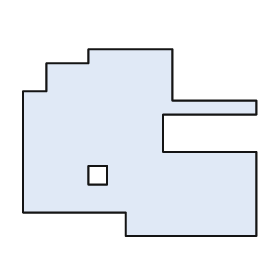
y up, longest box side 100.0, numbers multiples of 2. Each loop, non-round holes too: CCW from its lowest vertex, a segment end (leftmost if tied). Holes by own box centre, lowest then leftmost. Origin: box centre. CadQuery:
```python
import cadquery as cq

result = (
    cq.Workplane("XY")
    .moveTo(-6.0, -40.0)
    .lineTo(50.0, -40.0)
    .lineTo(50.0, -4.0)
    .lineTo(10.0, -4.0)
    .lineTo(10.0, 12.0)
    .lineTo(50.0, 12.0)
    .lineTo(50.0, 18.0)
    .lineTo(14.0, 18.0)
    .lineTo(14.0, 40.0)
    .lineTo(-22.0, 40.0)
    .lineTo(-22.0, 34.0)
    .lineTo(-40.0, 34.0)
    .lineTo(-40.0, 22.0)
    .lineTo(-50.0, 22.0)
    .lineTo(-50.0, -30.0)
    .lineTo(-6.0, -30.0)
    .close()
    .moveTo(-22.0, -18.0)
    .lineTo(-14.0, -18.0)
    .lineTo(-14.0, -10.0)
    .lineTo(-22.0, -10.0)
    .close()
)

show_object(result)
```